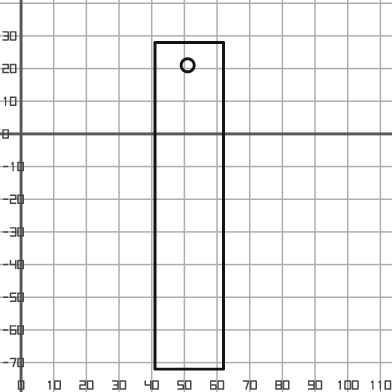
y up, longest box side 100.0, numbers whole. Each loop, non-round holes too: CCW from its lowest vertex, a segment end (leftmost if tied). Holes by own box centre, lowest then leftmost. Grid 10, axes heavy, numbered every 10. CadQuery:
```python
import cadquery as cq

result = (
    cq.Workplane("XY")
    .moveTo(41.0, -72.0)
    .lineTo(62.0, -72.0)
    .lineTo(62.0, 28.0)
    .lineTo(41.0, 28.0)
    .close()
    .moveTo(51.0, 21.0)
    .circle(2.0)
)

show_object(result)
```